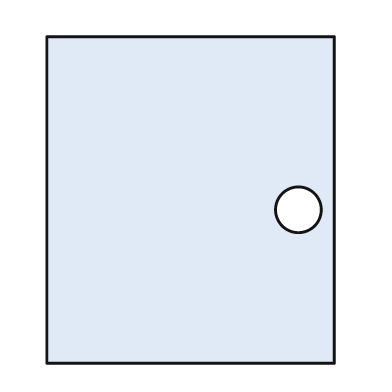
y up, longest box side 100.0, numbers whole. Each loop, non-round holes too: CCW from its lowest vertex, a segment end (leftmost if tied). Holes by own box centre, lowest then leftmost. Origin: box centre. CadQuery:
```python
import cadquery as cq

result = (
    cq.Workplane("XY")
    .moveTo(-44.0, -50.0)
    .lineTo(44.0, -50.0)
    .lineTo(44.0, 50.0)
    .lineTo(-44.0, 50.0)
    .close()
    .moveTo(33.0, -3.0)
    .circle(7.0)
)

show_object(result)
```